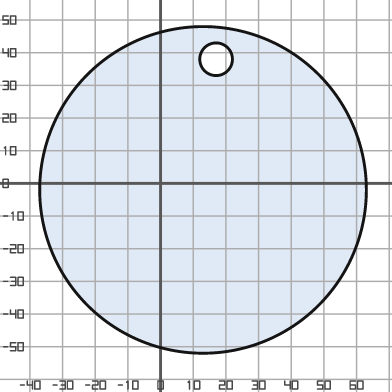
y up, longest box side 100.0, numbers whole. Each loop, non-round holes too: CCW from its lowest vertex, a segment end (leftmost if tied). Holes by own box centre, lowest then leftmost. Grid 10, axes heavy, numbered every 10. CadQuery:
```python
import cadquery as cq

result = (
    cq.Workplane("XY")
    .moveTo(13.0, -2.0)
    .circle(50.0)
    .moveTo(17.0, 38.0)
    .circle(5.0)
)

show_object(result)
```